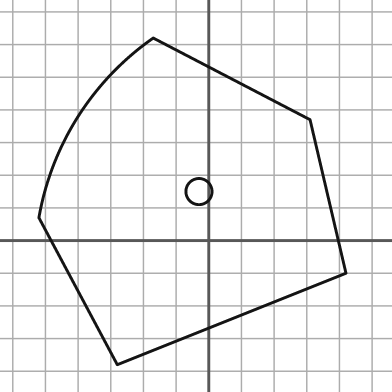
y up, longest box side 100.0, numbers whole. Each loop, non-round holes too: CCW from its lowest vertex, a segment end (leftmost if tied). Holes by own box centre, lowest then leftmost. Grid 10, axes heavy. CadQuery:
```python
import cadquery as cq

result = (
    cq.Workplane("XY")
    .moveTo(-28.0, -38.0)
    .lineTo(42.0, -10.0)
    .lineTo(31.0, 37.0)
    .lineTo(-17.0, 62.0)
    .threePointArc((-40.0, 38.0), (-52.0, 7.0))
    .close()
    .moveTo(-3.0, 15.0)
    .circle(4.0)
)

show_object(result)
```